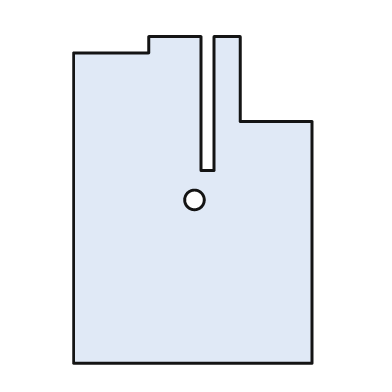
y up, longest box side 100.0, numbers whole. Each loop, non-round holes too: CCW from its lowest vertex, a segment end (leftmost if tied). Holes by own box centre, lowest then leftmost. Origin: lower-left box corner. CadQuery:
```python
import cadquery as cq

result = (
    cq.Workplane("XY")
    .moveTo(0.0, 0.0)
    .lineTo(73.0, 0.0)
    .lineTo(73.0, 74.0)
    .lineTo(51.0, 74.0)
    .lineTo(51.0, 100.0)
    .lineTo(43.0, 100.0)
    .lineTo(43.0, 59.0)
    .lineTo(39.0, 59.0)
    .lineTo(39.0, 100.0)
    .lineTo(23.0, 100.0)
    .lineTo(23.0, 95.0)
    .lineTo(0.0, 95.0)
    .close()
    .moveTo(37.0, 50.0)
    .circle(3.0)
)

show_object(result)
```